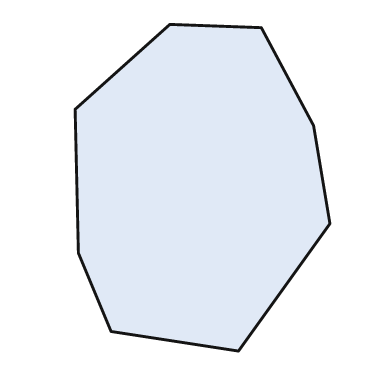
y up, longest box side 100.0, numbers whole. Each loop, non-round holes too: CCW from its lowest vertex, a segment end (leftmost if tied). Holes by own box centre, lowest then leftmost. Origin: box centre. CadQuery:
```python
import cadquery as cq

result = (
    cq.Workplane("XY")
    .moveTo(11.0, -50.0)
    .lineTo(39.0, -11.0)
    .lineTo(34.0, 19.0)
    .lineTo(18.0, 49.0)
    .lineTo(-10.0, 50.0)
    .lineTo(-39.0, 24.0)
    .lineTo(-38.0, -20.0)
    .lineTo(-28.0, -44.0)
    .close()
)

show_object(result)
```